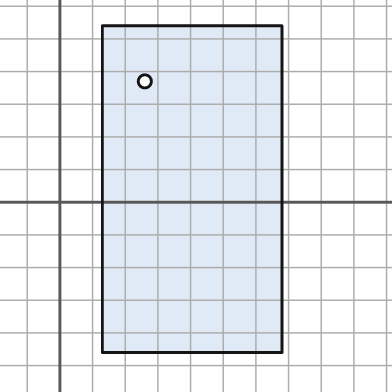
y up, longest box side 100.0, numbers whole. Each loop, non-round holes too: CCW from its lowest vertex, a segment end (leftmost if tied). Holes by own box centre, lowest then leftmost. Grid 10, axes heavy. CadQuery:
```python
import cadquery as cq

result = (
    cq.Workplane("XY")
    .moveTo(13.0, -46.0)
    .lineTo(68.0, -46.0)
    .lineTo(68.0, 54.0)
    .lineTo(13.0, 54.0)
    .close()
    .moveTo(26.0, 37.0)
    .circle(2.0)
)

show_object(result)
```